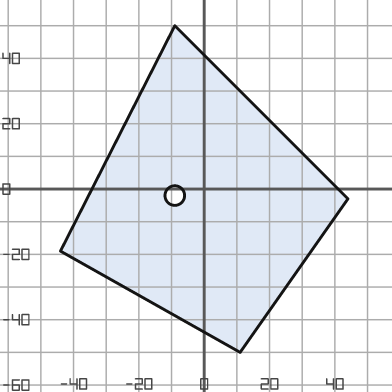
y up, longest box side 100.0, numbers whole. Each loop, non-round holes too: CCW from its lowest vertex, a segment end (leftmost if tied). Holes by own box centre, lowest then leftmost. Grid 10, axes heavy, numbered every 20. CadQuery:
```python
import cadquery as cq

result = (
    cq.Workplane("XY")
    .moveTo(11.0, -50.0)
    .lineTo(44.0, -3.0)
    .lineTo(-9.0, 50.0)
    .lineTo(-44.0, -19.0)
    .close()
    .moveTo(-9.0, -2.0)
    .circle(3.0)
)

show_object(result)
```